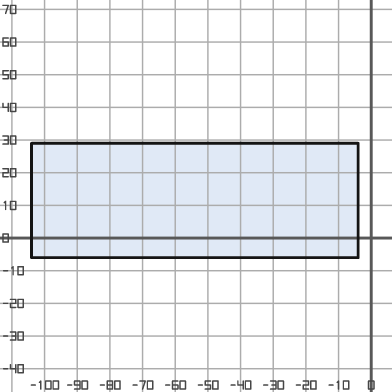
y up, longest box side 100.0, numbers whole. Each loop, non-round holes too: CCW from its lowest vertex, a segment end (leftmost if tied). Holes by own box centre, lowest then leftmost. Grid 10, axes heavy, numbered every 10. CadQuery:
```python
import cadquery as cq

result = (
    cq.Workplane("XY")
    .moveTo(-104.0, -6.0)
    .lineTo(-4.0, -6.0)
    .lineTo(-4.0, 29.0)
    .lineTo(-104.0, 29.0)
    .close()
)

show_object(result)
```